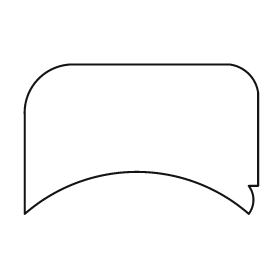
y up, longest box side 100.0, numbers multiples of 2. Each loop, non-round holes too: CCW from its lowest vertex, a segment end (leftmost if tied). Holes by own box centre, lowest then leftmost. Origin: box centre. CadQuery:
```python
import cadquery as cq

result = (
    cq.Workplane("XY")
    .moveTo(-50.0, -32.0)
    .threePointArc((-2.0, -14.0), (46.0, -32.0))
    .threePointArc((48.0, -26.0), (46.0, -20.0))
    .lineTo(50.0, -20.0)
    .lineTo(50.0, 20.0)
    .threePointArc((46.0, 28.0), (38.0, 32.0))
    .lineTo(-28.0, 32.0)
    .threePointArc((-44.0, 26.0), (-50.0, 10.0))
    .close()
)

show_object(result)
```